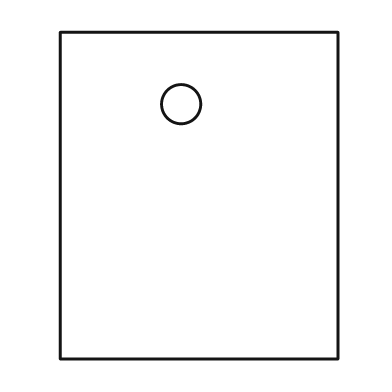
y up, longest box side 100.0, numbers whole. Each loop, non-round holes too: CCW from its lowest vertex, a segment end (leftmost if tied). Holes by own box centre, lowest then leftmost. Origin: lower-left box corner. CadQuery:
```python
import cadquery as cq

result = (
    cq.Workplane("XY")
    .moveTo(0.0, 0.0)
    .lineTo(85.0, 0.0)
    .lineTo(85.0, 100.0)
    .lineTo(0.0, 100.0)
    .close()
    .moveTo(37.0, 78.0)
    .circle(6.0)
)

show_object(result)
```